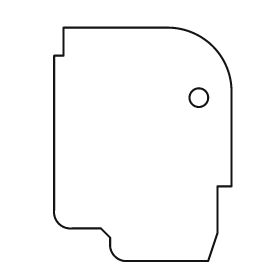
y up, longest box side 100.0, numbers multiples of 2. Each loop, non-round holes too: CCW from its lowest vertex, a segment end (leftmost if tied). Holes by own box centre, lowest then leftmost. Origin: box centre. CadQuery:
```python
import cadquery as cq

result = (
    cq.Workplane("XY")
    .moveTo(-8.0, -50.0)
    .lineTo(28.0, -50.0)
    .lineTo(32.0, -38.0)
    .lineTo(32.0, -18.0)
    .lineTo(38.0, -18.0)
    .lineTo(38.0, 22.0)
    .threePointArc((30.0, 42.0), (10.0, 50.0))
    .lineTo(-34.0, 50.0)
    .lineTo(-34.0, 38.0)
    .lineTo(-38.0, 38.0)
    .lineTo(-38.0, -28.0)
    .threePointArc((-36.0, -34.0), (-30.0, -36.0))
    .lineTo(-18.0, -36.0)
    .lineTo(-14.0, -40.0)
    .lineTo(-14.0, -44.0)
    .threePointArc((-12.0, -48.0), (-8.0, -50.0))
    .close()
    .moveTo(24.0, 20.0)
    .circle(4.0)
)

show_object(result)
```